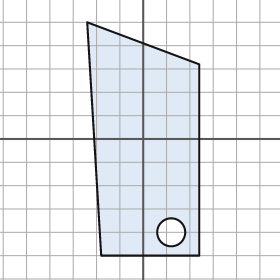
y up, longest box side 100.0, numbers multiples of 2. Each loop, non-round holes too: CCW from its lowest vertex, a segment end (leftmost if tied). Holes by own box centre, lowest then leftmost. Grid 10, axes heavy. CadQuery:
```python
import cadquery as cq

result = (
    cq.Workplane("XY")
    .moveTo(-18.0, -50.0)
    .lineTo(24.0, -50.0)
    .lineTo(24.0, 32.0)
    .lineTo(-24.0, 50.0)
    .close()
    .moveTo(12.0, -40.0)
    .circle(6.0)
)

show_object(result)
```